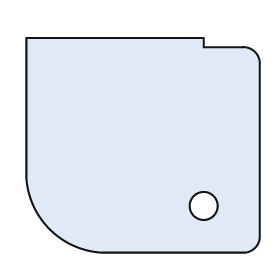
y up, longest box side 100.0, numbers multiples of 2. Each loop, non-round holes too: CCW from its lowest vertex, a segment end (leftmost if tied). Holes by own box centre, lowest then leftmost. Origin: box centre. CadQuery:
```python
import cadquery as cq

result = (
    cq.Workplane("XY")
    .moveTo(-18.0, -46.0)
    .lineTo(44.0, -46.0)
    .threePointArc((48.0, -44.0), (50.0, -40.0))
    .lineTo(50.0, 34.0)
    .threePointArc((48.0, 40.0), (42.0, 42.0))
    .lineTo(26.0, 42.0)
    .lineTo(26.0, 46.0)
    .lineTo(-50.0, 46.0)
    .lineTo(-50.0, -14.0)
    .threePointArc((-40.0, -36.0), (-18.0, -46.0))
    .close()
    .moveTo(26.0, -26.0)
    .circle(6.0)
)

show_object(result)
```